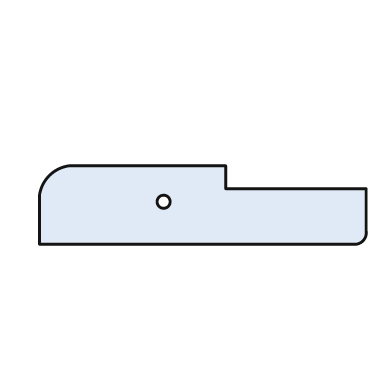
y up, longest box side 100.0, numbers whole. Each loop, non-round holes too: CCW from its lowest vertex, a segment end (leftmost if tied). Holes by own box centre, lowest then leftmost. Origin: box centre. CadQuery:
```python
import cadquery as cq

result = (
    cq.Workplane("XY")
    .moveTo(-50.0, -12.0)
    .lineTo(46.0, -12.0)
    .threePointArc((49.0, -11.0), (50.0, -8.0))
    .lineTo(50.0, 5.0)
    .lineTo(7.0, 5.0)
    .lineTo(7.0, 12.0)
    .lineTo(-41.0, 12.0)
    .threePointArc((-47.0, 9.0), (-50.0, 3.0))
    .close()
    .moveTo(-12.0, 1.0)
    .circle(2.0)
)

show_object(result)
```